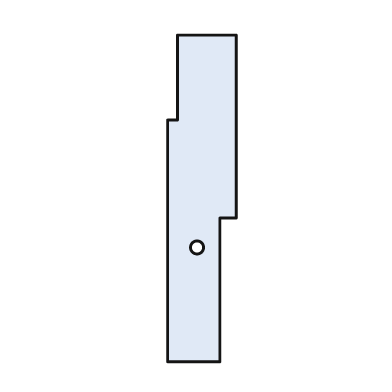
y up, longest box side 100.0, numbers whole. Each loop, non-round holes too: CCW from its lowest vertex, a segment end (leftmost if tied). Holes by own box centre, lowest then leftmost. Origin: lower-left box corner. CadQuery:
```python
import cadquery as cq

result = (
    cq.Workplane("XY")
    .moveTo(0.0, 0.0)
    .lineTo(16.0, 0.0)
    .lineTo(16.0, 44.0)
    .lineTo(21.0, 44.0)
    .lineTo(21.0, 100.0)
    .lineTo(3.0, 100.0)
    .lineTo(3.0, 74.0)
    .lineTo(0.0, 74.0)
    .close()
    .moveTo(9.0, 35.0)
    .circle(2.0)
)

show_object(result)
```